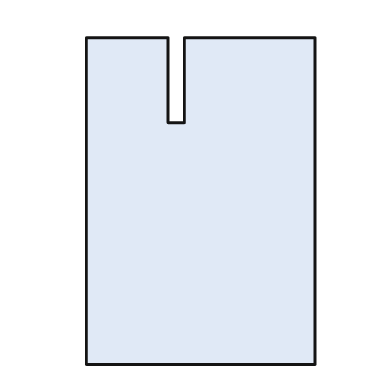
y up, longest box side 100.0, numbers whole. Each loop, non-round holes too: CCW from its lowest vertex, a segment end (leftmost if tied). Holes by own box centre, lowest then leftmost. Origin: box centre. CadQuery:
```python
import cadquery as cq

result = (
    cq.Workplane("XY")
    .moveTo(-35.0, -50.0)
    .lineTo(35.0, -50.0)
    .lineTo(35.0, 50.0)
    .lineTo(-5.0, 50.0)
    .lineTo(-5.0, 24.0)
    .lineTo(-10.0, 24.0)
    .lineTo(-10.0, 50.0)
    .lineTo(-35.0, 50.0)
    .close()
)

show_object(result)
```